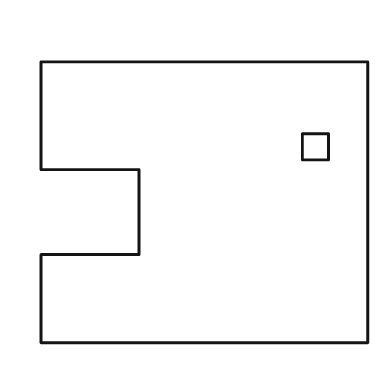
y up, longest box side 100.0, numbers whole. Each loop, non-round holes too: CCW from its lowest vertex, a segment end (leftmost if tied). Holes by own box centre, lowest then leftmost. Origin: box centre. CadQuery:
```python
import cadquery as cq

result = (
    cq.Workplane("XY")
    .moveTo(-50.0, -43.0)
    .lineTo(50.0, -43.0)
    .lineTo(50.0, 43.0)
    .lineTo(-50.0, 43.0)
    .lineTo(-50.0, 10.0)
    .lineTo(-20.0, 10.0)
    .lineTo(-20.0, -16.0)
    .lineTo(-50.0, -16.0)
    .close()
    .moveTo(30.0, 13.0)
    .lineTo(38.0, 13.0)
    .lineTo(38.0, 21.0)
    .lineTo(30.0, 21.0)
    .close()
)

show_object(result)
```